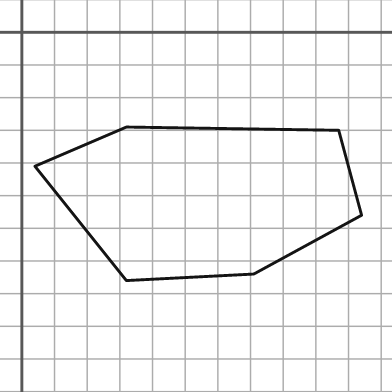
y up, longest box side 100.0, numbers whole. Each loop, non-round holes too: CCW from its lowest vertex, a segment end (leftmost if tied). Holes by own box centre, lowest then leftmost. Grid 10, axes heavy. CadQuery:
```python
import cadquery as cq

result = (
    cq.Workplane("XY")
    .moveTo(32.0, -76.0)
    .lineTo(71.0, -74.0)
    .lineTo(104.0, -56.0)
    .lineTo(97.0, -30.0)
    .lineTo(32.0, -29.0)
    .lineTo(4.0, -41.0)
    .close()
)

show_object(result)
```